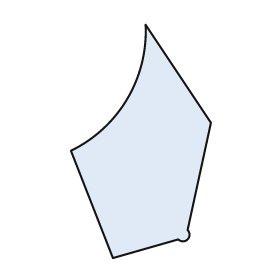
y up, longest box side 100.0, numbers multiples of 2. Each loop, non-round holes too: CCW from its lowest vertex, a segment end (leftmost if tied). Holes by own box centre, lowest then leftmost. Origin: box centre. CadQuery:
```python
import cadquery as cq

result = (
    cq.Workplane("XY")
    .moveTo(-12.0, -50.0)
    .lineTo(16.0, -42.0)
    .threePointArc((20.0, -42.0), (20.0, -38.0))
    .lineTo(30.0, 8.0)
    .lineTo(2.0, 50.0)
    .threePointArc((-6.0, 18.0), (-30.0, -4.0))
    .close()
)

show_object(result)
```